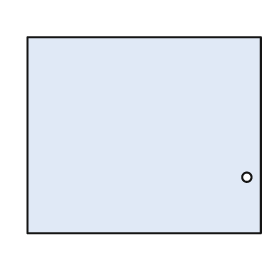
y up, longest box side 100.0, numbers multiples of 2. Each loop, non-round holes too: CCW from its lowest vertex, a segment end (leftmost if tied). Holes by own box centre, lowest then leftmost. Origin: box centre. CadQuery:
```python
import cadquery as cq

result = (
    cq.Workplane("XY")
    .moveTo(-50.0, -42.0)
    .lineTo(50.0, -42.0)
    .lineTo(50.0, 42.0)
    .lineTo(-50.0, 42.0)
    .close()
    .moveTo(44.0, -18.0)
    .circle(2.0)
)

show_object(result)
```